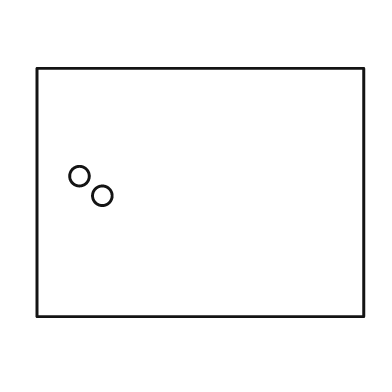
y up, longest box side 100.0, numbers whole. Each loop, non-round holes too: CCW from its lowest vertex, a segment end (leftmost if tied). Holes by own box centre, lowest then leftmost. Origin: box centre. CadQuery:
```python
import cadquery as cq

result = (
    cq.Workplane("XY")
    .moveTo(-50.0, -38.0)
    .lineTo(50.0, -38.0)
    .lineTo(50.0, 38.0)
    .lineTo(-50.0, 38.0)
    .close()
    .moveTo(-30.0, -1.0)
    .circle(3.0)
    .moveTo(-37.0, 5.0)
    .circle(3.0)
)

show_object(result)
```